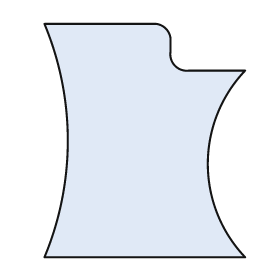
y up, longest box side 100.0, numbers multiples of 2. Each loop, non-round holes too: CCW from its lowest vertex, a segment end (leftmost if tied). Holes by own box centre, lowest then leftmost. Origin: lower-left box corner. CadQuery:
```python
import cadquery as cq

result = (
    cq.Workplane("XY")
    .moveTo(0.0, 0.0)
    .lineTo(86.0, 0.0)
    .threePointArc((70.0, 40.0), (86.0, 80.0))
    .lineTo(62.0, 80.0)
    .threePointArc((56.0, 82.0), (54.0, 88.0))
    .lineTo(54.0, 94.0)
    .threePointArc((52.0, 98.0), (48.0, 100.0))
    .lineTo(0.0, 100.0)
    .threePointArc((10.0, 50.0), (0.0, 0.0))
    .close()
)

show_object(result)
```